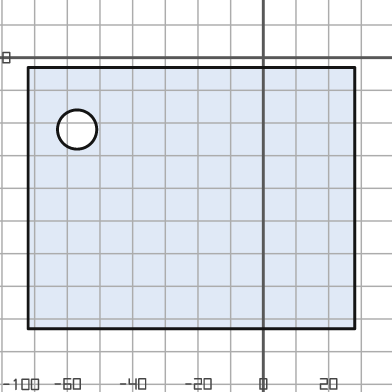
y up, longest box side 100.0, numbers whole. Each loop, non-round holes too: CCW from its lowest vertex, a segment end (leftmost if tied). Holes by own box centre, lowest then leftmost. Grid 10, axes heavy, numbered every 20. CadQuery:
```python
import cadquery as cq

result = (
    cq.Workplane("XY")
    .moveTo(-72.0, -83.0)
    .lineTo(28.0, -83.0)
    .lineTo(28.0, -3.0)
    .lineTo(-72.0, -3.0)
    .close()
    .moveTo(-57.0, -22.0)
    .circle(6.0)
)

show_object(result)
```